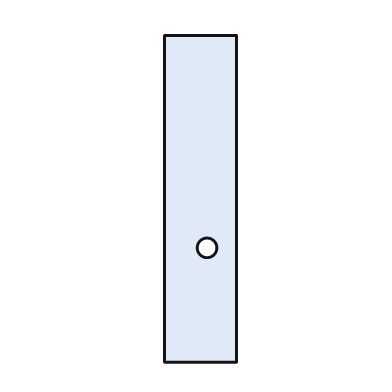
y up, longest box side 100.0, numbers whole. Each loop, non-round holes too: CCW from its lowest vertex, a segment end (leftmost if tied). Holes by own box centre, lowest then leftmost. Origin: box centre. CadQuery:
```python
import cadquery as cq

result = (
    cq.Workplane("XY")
    .moveTo(-11.0, -50.0)
    .lineTo(11.0, -50.0)
    .lineTo(11.0, 50.0)
    .lineTo(-11.0, 50.0)
    .close()
    .moveTo(2.0, -15.0)
    .circle(3.0)
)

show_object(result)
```